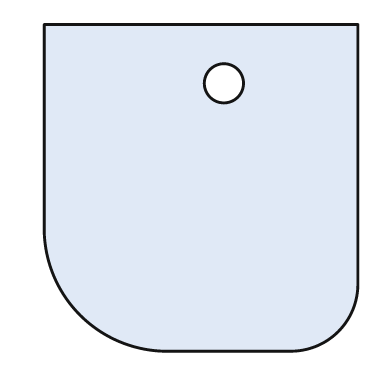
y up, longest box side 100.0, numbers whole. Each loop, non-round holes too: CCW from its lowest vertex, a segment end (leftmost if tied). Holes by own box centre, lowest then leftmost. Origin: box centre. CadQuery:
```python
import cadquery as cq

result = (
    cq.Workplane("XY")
    .moveTo(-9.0, -50.0)
    .lineTo(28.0, -50.0)
    .threePointArc((42.0, -44.0), (48.0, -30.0))
    .lineTo(48.0, 50.0)
    .lineTo(-48.0, 50.0)
    .lineTo(-48.0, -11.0)
    .threePointArc((-37.0, -39.0), (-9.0, -50.0))
    .close()
    .moveTo(7.0, 32.0)
    .circle(6.0)
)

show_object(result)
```